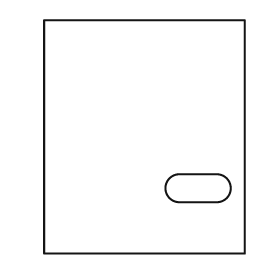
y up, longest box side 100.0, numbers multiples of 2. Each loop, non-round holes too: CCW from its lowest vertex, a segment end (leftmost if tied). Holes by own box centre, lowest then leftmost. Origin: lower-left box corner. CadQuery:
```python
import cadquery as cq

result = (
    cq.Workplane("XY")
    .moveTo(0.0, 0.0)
    .lineTo(86.0, 0.0)
    .lineTo(86.0, 100.0)
    .lineTo(0.0, 100.0)
    .close()
    .moveTo(58.0, 22.0)
    .lineTo(74.0, 22.0)
    .threePointArc((80.0, 28.0), (74.0, 34.0))
    .lineTo(58.0, 34.0)
    .threePointArc((52.0, 28.0), (58.0, 22.0))
    .close()
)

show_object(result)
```